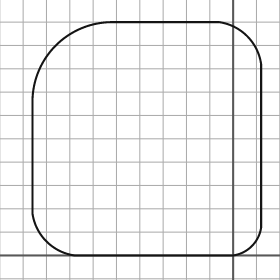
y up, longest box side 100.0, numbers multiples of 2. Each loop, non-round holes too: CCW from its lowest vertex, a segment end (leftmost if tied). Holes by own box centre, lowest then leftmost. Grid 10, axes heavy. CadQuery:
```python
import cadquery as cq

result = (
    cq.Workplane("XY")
    .moveTo(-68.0, 0.0)
    .lineTo(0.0, 0.0)
    .threePointArc((8.0, 4.0), (12.0, 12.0))
    .lineTo(12.0, 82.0)
    .threePointArc((6.0, 94.0), (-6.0, 100.0))
    .lineTo(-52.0, 100.0)
    .threePointArc((-76.0, 90.0), (-86.0, 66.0))
    .lineTo(-86.0, 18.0)
    .threePointArc((-80.0, 6.0), (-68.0, 0.0))
    .close()
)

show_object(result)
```